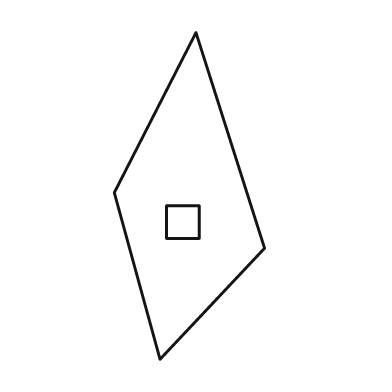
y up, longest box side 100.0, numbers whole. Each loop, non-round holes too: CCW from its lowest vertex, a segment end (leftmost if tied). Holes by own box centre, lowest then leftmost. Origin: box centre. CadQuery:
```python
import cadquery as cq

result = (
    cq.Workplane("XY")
    .moveTo(-9.0, -50.0)
    .lineTo(23.0, -16.0)
    .lineTo(2.0, 50.0)
    .lineTo(-23.0, 1.0)
    .close()
    .moveTo(-7.0, -13.0)
    .lineTo(3.0, -13.0)
    .lineTo(3.0, -3.0)
    .lineTo(-7.0, -3.0)
    .close()
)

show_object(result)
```